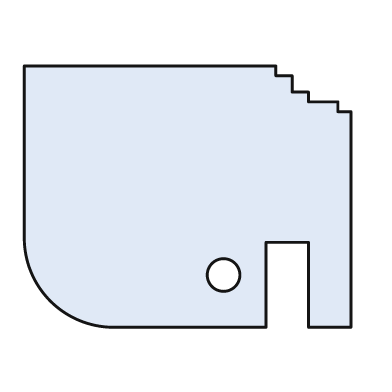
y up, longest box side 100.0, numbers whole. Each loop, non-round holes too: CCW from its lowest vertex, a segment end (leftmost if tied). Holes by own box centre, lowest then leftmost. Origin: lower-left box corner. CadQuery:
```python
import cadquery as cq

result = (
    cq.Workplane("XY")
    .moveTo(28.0, 0.0)
    .lineTo(74.0, 0.0)
    .lineTo(74.0, 26.0)
    .lineTo(87.0, 26.0)
    .lineTo(87.0, 0.0)
    .lineTo(100.0, 0.0)
    .lineTo(100.0, 66.0)
    .lineTo(96.0, 66.0)
    .lineTo(96.0, 69.0)
    .lineTo(87.0, 69.0)
    .lineTo(87.0, 72.0)
    .lineTo(82.0, 72.0)
    .lineTo(82.0, 77.0)
    .lineTo(77.0, 77.0)
    .lineTo(77.0, 80.0)
    .lineTo(0.0, 80.0)
    .lineTo(0.0, 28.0)
    .threePointArc((8.0, 8.0), (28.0, 0.0))
    .close()
    .moveTo(61.0, 16.0)
    .circle(5.0)
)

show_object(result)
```